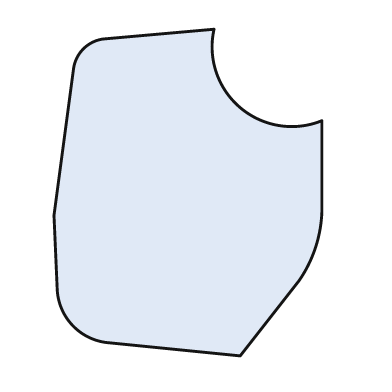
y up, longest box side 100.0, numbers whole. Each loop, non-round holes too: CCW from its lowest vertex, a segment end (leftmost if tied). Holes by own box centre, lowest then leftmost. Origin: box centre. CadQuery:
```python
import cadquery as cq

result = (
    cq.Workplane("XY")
    .moveTo(16.0, -50.0)
    .lineTo(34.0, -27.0)
    .threePointArc((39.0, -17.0), (41.0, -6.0))
    .lineTo(41.0, 22.0)
    .threePointArc((16.0, 26.0), (8.0, 50.0))
    .lineTo(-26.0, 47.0)
    .threePointArc((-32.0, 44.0), (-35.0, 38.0))
    .lineTo(-41.0, -7.0)
    .lineTo(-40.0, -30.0)
    .threePointArc((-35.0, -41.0), (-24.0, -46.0))
    .close()
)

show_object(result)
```